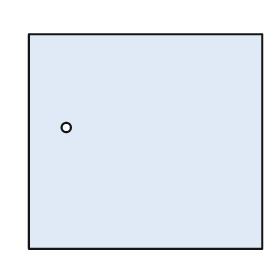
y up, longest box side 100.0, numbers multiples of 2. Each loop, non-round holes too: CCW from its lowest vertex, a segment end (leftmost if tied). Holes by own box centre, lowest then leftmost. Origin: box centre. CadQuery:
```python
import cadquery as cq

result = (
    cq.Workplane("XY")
    .moveTo(-50.0, -46.0)
    .lineTo(50.0, -46.0)
    .lineTo(50.0, 46.0)
    .lineTo(-50.0, 46.0)
    .close()
    .moveTo(-34.0, 6.0)
    .circle(2.0)
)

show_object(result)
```